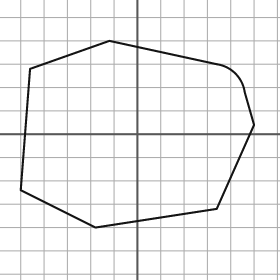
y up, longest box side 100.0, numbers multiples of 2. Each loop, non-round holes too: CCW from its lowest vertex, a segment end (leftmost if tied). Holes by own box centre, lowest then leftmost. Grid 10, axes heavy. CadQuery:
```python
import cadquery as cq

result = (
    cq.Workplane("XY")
    .moveTo(-18.0, -40.0)
    .lineTo(34.0, -32.0)
    .lineTo(50.0, 4.0)
    .lineTo(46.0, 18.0)
    .threePointArc((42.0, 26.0), (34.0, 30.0))
    .lineTo(-12.0, 40.0)
    .lineTo(-46.0, 28.0)
    .lineTo(-50.0, -24.0)
    .close()
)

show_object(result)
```